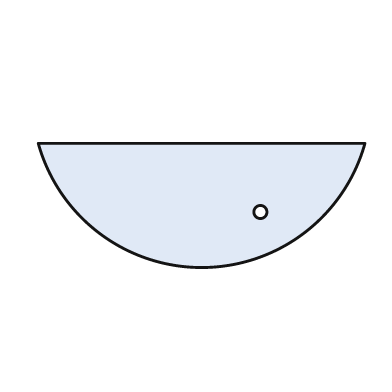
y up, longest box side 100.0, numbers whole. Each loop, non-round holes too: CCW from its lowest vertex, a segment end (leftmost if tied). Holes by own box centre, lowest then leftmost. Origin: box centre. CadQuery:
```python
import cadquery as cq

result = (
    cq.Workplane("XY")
    .moveTo(-50.0, 19.0)
    .threePointArc((0.0, -19.0), (50.0, 19.0))
    .close()
    .moveTo(18.0, -2.0)
    .circle(2.0)
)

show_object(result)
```